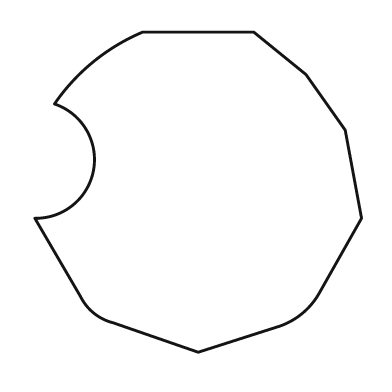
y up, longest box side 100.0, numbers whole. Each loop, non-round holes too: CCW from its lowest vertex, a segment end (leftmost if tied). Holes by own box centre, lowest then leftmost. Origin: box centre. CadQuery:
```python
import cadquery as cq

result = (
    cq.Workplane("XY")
    .moveTo(0.0, -49.0)
    .lineTo(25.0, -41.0)
    .threePointArc((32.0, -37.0), (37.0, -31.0))
    .lineTo(50.0, -8.0)
    .lineTo(45.0, 19.0)
    .lineTo(33.0, 36.0)
    .lineTo(17.0, 49.0)
    .lineTo(-17.0, 49.0)
    .threePointArc((-32.0, 40.0), (-44.0, 27.0))
    .threePointArc((-32.0, 7.0), (-50.0, -8.0))
    .lineTo(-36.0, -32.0)
    .threePointArc((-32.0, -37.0), (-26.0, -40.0))
    .close()
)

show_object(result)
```